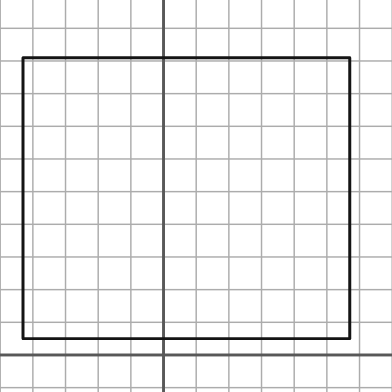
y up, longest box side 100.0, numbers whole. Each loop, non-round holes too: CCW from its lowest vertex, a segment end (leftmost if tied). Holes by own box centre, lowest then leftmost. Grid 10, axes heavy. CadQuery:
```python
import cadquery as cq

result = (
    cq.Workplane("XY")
    .moveTo(-43.0, 5.0)
    .lineTo(57.0, 5.0)
    .lineTo(57.0, 91.0)
    .lineTo(-43.0, 91.0)
    .close()
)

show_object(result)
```